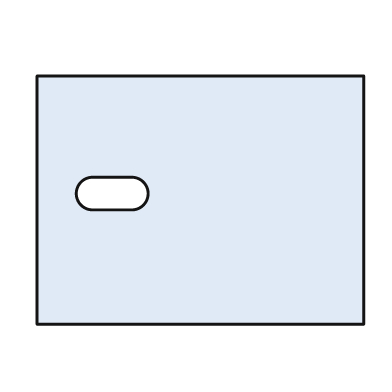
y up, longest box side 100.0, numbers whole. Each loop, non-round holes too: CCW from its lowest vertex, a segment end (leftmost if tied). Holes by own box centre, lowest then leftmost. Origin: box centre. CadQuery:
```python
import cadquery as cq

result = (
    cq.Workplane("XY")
    .moveTo(-50.0, -38.0)
    .lineTo(50.0, -38.0)
    .lineTo(50.0, 38.0)
    .lineTo(-50.0, 38.0)
    .close()
    .moveTo(-33.0, -3.0)
    .lineTo(-21.0, -3.0)
    .threePointArc((-16.0, 2.0), (-21.0, 7.0))
    .lineTo(-33.0, 7.0)
    .threePointArc((-38.0, 2.0), (-33.0, -3.0))
    .close()
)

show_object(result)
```